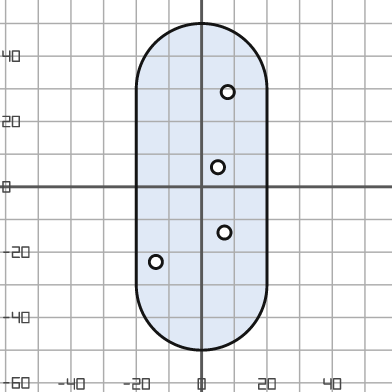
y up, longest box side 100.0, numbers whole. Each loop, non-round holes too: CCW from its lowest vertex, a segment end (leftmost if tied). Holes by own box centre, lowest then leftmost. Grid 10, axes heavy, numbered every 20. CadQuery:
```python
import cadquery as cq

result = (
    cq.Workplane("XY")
    .moveTo(-20.0, -30.0)
    .threePointArc((0.0, -50.0), (20.0, -30.0))
    .lineTo(20.0, 30.0)
    .threePointArc((0.0, 50.0), (-20.0, 30.0))
    .close()
    .moveTo(-14.0, -23.0)
    .circle(2.0)
    .moveTo(7.0, -14.0)
    .circle(2.0)
    .moveTo(5.0, 6.0)
    .circle(2.0)
    .moveTo(8.0, 29.0)
    .circle(2.0)
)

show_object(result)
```